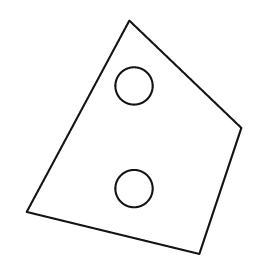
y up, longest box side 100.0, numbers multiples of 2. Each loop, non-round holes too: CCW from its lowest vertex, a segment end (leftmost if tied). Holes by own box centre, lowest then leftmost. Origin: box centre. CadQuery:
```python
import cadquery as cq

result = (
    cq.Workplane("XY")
    .moveTo(28.0, -50.0)
    .lineTo(46.0, 4.0)
    .lineTo(-2.0, 50.0)
    .lineTo(-46.0, -32.0)
    .close()
    .moveTo(0.0, -22.0)
    .circle(8.0)
    .moveTo(0.0, 22.0)
    .circle(8.0)
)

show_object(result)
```